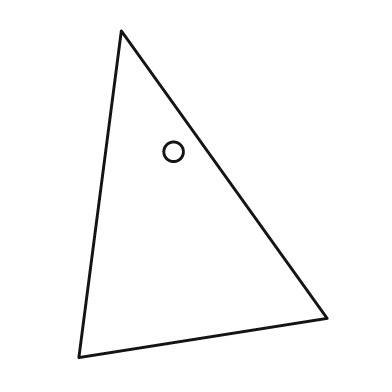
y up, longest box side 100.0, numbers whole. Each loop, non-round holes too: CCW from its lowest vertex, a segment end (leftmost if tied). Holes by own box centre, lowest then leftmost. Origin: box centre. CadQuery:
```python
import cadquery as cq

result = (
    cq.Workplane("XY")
    .moveTo(-38.0, -50.0)
    .lineTo(38.0, -38.0)
    .lineTo(-25.0, 50.0)
    .close()
    .moveTo(-9.0, 13.0)
    .circle(3.0)
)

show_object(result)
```